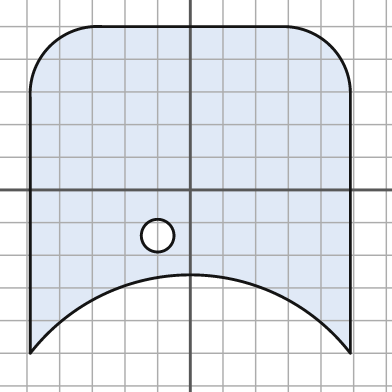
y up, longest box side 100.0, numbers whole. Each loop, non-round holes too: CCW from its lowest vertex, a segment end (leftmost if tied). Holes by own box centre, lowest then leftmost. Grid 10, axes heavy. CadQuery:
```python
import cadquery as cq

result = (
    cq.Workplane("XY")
    .moveTo(-49.0, -50.0)
    .threePointArc((0.0, -26.0), (49.0, -50.0))
    .lineTo(49.0, 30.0)
    .threePointArc((43.0, 44.0), (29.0, 50.0))
    .lineTo(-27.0, 50.0)
    .threePointArc((-43.0, 44.0), (-49.0, 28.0))
    .close()
    .moveTo(-10.0, -14.0)
    .circle(5.0)
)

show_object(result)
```